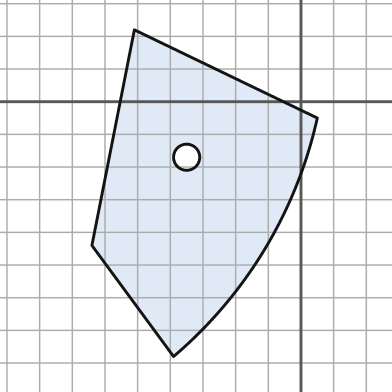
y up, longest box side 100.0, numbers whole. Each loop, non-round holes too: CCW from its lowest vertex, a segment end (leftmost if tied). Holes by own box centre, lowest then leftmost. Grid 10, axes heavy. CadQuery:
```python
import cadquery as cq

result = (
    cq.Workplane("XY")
    .moveTo(-39.0, -78.0)
    .threePointArc((-11.0, -45.0), (5.0, -5.0))
    .lineTo(-51.0, 22.0)
    .lineTo(-64.0, -44.0)
    .close()
    .moveTo(-35.0, -17.0)
    .circle(4.0)
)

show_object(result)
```